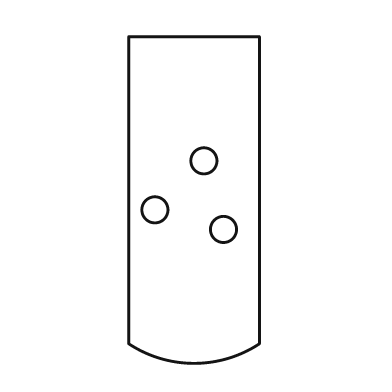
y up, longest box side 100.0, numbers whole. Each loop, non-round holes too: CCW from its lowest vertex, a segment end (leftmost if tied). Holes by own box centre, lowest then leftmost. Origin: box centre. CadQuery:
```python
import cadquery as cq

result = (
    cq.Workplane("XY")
    .moveTo(-20.0, -44.0)
    .threePointArc((0.0, -50.0), (20.0, -44.0))
    .lineTo(20.0, 50.0)
    .lineTo(-20.0, 50.0)
    .close()
    .moveTo(9.0, -9.0)
    .circle(4.0)
    .moveTo(-12.0, -3.0)
    .circle(4.0)
    .moveTo(3.0, 12.0)
    .circle(4.0)
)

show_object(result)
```